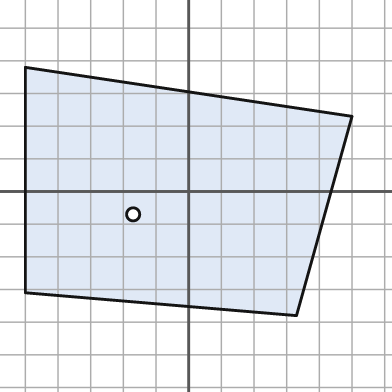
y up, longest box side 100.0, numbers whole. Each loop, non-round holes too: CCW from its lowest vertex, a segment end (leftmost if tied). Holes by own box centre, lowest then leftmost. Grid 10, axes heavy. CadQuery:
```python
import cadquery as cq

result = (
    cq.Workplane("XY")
    .moveTo(33.0, -38.0)
    .lineTo(50.0, 23.0)
    .lineTo(-50.0, 38.0)
    .lineTo(-50.0, -31.0)
    .close()
    .moveTo(-17.0, -7.0)
    .circle(2.0)
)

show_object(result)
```